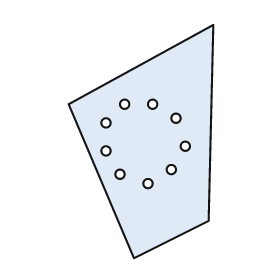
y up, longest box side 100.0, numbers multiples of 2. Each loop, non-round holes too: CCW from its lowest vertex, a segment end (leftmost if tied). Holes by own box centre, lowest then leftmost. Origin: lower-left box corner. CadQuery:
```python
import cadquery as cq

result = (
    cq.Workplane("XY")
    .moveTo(28.0, 0.0)
    .lineTo(60.0, 16.0)
    .lineTo(62.0, 100.0)
    .lineTo(0.0, 66.0)
    .close()
    .moveTo(34.0, 32.0)
    .circle(2.0)
    .moveTo(22.0, 36.0)
    .circle(2.0)
    .moveTo(44.0, 38.0)
    .circle(2.0)
    .moveTo(16.0, 46.0)
    .circle(2.0)
    .moveTo(50.0, 48.0)
    .circle(2.0)
    .moveTo(16.0, 58.0)
    .circle(2.0)
    .moveTo(46.0, 60.0)
    .circle(2.0)
    .moveTo(24.0, 66.0)
    .circle(2.0)
    .moveTo(36.0, 66.0)
    .circle(2.0)
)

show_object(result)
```